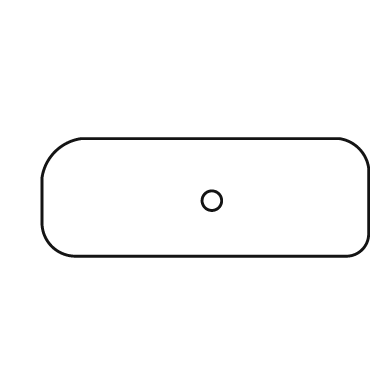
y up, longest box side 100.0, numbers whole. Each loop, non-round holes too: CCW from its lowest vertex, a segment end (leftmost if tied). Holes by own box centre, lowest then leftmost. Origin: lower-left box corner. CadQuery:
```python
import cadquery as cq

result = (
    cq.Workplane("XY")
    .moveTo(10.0, 0.0)
    .lineTo(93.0, 0.0)
    .threePointArc((98.0, 2.0), (100.0, 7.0))
    .lineTo(100.0, 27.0)
    .threePointArc((97.0, 33.0), (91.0, 36.0))
    .lineTo(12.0, 36.0)
    .threePointArc((4.0, 32.0), (0.0, 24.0))
    .lineTo(0.0, 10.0)
    .threePointArc((3.0, 3.0), (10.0, 0.0))
    .close()
    .moveTo(52.0, 17.0)
    .circle(3.0)
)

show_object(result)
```